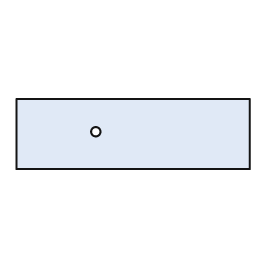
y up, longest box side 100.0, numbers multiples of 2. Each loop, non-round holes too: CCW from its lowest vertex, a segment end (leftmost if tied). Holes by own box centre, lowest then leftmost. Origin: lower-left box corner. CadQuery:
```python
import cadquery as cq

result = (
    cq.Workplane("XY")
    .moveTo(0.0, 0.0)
    .lineTo(100.0, 0.0)
    .lineTo(100.0, 30.0)
    .lineTo(0.0, 30.0)
    .close()
    .moveTo(34.0, 16.0)
    .circle(2.0)
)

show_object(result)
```